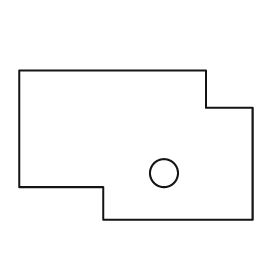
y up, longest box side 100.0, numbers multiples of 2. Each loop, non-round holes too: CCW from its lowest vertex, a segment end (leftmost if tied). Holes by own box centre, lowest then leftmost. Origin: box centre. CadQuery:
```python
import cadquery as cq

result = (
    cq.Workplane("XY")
    .moveTo(-14.0, -32.0)
    .lineTo(50.0, -32.0)
    .lineTo(50.0, 16.0)
    .lineTo(30.0, 16.0)
    .lineTo(30.0, 32.0)
    .lineTo(-50.0, 32.0)
    .lineTo(-50.0, -18.0)
    .lineTo(-14.0, -18.0)
    .close()
    .moveTo(12.0, -12.0)
    .circle(6.0)
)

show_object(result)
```